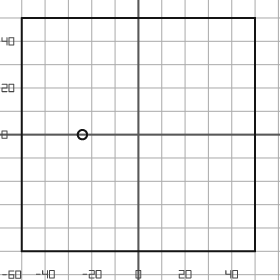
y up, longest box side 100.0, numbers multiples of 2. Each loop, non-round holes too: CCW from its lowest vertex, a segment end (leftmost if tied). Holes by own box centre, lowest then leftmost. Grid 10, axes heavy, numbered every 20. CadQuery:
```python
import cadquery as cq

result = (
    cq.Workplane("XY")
    .moveTo(-50.0, -50.0)
    .lineTo(50.0, -50.0)
    .lineTo(50.0, 50.0)
    .lineTo(-50.0, 50.0)
    .close()
    .moveTo(-24.0, 0.0)
    .circle(2.0)
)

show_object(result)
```